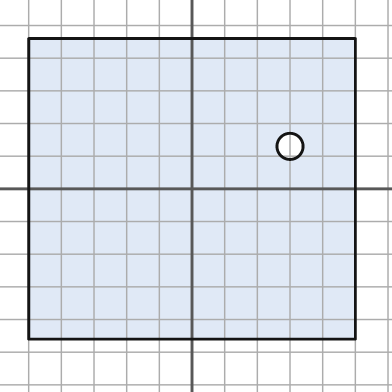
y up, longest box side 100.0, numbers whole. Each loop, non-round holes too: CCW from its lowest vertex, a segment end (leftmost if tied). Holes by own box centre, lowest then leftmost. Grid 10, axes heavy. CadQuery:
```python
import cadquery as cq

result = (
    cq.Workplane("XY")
    .moveTo(-50.0, -46.0)
    .lineTo(50.0, -46.0)
    .lineTo(50.0, 46.0)
    .lineTo(-50.0, 46.0)
    .close()
    .moveTo(30.0, 13.0)
    .circle(4.0)
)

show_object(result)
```